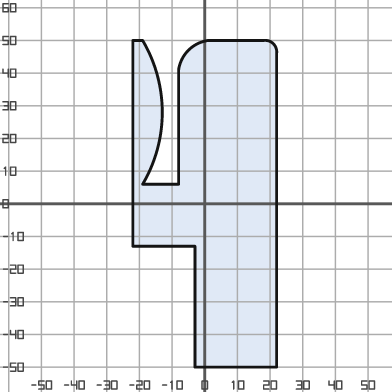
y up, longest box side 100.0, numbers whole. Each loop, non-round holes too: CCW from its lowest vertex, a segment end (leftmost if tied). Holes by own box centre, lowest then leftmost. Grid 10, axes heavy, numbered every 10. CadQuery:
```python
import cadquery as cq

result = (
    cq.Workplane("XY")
    .moveTo(-3.0, -50.0)
    .lineTo(22.0, -50.0)
    .lineTo(22.0, 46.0)
    .threePointArc((21.0, 49.0), (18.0, 50.0))
    .lineTo(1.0, 50.0)
    .threePointArc((-5.0, 47.0), (-8.0, 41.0))
    .lineTo(-8.0, 6.0)
    .lineTo(-19.0, 6.0)
    .threePointArc((-13.0, 28.0), (-19.0, 50.0))
    .lineTo(-22.0, 50.0)
    .lineTo(-22.0, -13.0)
    .lineTo(-3.0, -13.0)
    .close()
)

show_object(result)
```